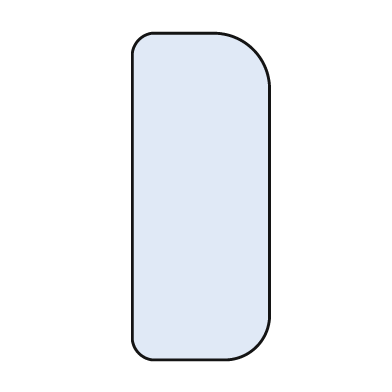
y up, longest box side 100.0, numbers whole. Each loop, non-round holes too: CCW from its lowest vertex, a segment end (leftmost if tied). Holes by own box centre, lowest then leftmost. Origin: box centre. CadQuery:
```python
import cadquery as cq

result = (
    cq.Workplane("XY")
    .moveTo(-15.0, -50.0)
    .lineTo(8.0, -50.0)
    .threePointArc((17.0, -46.0), (21.0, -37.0))
    .lineTo(21.0, 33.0)
    .threePointArc((16.0, 45.0), (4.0, 50.0))
    .lineTo(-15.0, 50.0)
    .threePointArc((-19.0, 48.0), (-21.0, 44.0))
    .lineTo(-21.0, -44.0)
    .threePointArc((-19.0, -48.0), (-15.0, -50.0))
    .close()
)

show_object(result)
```